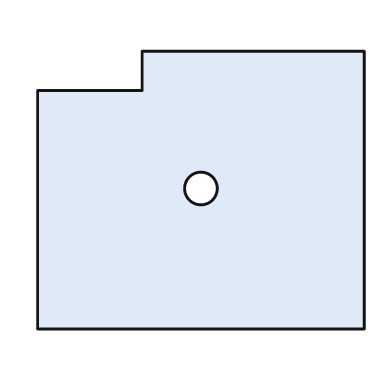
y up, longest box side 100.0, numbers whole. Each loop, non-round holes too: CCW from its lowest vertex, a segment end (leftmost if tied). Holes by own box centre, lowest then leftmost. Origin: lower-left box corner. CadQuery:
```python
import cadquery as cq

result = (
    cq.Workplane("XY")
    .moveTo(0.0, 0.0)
    .lineTo(100.0, 0.0)
    .lineTo(100.0, 85.0)
    .lineTo(32.0, 85.0)
    .lineTo(32.0, 73.0)
    .lineTo(0.0, 73.0)
    .close()
    .moveTo(50.0, 43.0)
    .circle(5.0)
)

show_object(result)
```